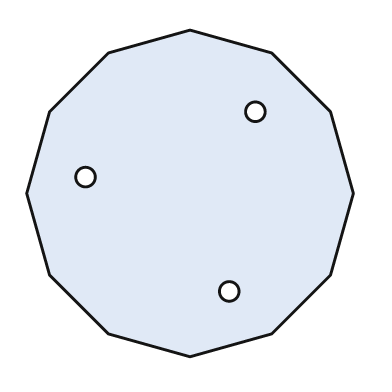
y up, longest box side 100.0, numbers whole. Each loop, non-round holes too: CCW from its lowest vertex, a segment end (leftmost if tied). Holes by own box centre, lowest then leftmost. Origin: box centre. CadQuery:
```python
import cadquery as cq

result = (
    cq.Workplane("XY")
    .moveTo(0.0, -50.0)
    .lineTo(25.0, -43.0)
    .lineTo(43.0, -25.0)
    .lineTo(50.0, 0.0)
    .lineTo(43.0, 25.0)
    .lineTo(25.0, 43.0)
    .lineTo(0.0, 50.0)
    .lineTo(-25.0, 43.0)
    .lineTo(-43.0, 25.0)
    .lineTo(-50.0, 0.0)
    .lineTo(-43.0, -25.0)
    .lineTo(-25.0, -43.0)
    .close()
    .moveTo(12.0, -30.0)
    .circle(3.0)
    .moveTo(-32.0, 5.0)
    .circle(3.0)
    .moveTo(20.0, 25.0)
    .circle(3.0)
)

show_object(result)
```